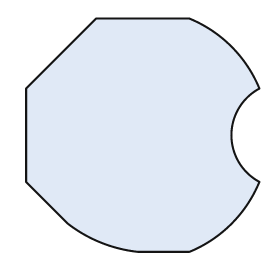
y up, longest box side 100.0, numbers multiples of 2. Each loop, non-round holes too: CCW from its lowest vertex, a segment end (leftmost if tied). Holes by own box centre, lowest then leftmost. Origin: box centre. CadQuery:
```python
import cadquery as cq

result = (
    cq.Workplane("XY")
    .moveTo(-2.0, -50.0)
    .lineTo(20.0, -50.0)
    .threePointArc((38.0, -38.0), (50.0, -20.0))
    .threePointArc((38.0, 0.0), (50.0, 20.0))
    .threePointArc((38.0, 38.0), (20.0, 50.0))
    .lineTo(-20.0, 50.0)
    .lineTo(-50.0, 20.0)
    .lineTo(-50.0, -20.0)
    .lineTo(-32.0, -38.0)
    .threePointArc((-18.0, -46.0), (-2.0, -50.0))
    .close()
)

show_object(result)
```